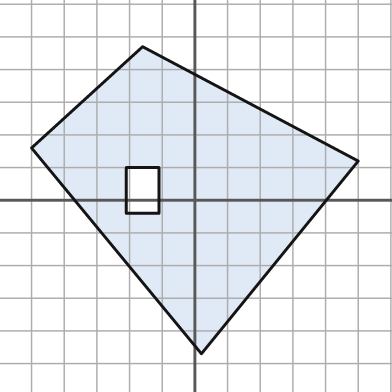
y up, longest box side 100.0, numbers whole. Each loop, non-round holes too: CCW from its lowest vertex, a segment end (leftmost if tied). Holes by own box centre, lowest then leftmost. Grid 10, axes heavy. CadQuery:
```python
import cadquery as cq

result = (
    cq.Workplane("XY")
    .moveTo(2.0, -47.0)
    .lineTo(50.0, 12.0)
    .lineTo(-16.0, 47.0)
    .lineTo(-50.0, 16.0)
    .close()
    .moveTo(-21.0, -4.0)
    .lineTo(-11.0, -4.0)
    .lineTo(-11.0, 10.0)
    .lineTo(-21.0, 10.0)
    .close()
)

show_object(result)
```